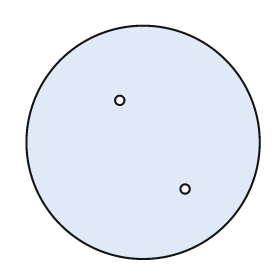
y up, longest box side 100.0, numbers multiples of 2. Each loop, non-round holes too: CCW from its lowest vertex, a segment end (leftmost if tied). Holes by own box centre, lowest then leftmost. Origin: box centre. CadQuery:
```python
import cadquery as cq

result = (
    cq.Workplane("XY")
    .moveTo(0.0, 0.0)
    .circle(50.0)
    .moveTo(18.0, -20.0)
    .circle(2.0)
    .moveTo(-10.0, 18.0)
    .circle(2.0)
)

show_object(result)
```